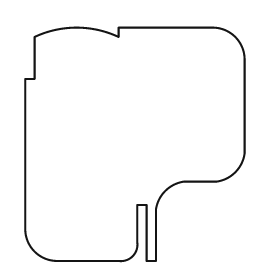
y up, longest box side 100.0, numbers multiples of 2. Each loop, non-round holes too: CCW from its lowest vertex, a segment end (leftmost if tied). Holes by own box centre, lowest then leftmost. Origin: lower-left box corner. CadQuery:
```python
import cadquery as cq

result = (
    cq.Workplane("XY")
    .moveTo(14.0, 0.0)
    .lineTo(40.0, 0.0)
    .threePointArc((46.0, 2.0), (48.0, 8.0))
    .lineTo(48.0, 24.0)
    .lineTo(52.0, 24.0)
    .lineTo(52.0, 0.0)
    .lineTo(56.0, 0.0)
    .lineTo(56.0, 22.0)
    .threePointArc((60.0, 30.0), (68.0, 34.0))
    .lineTo(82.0, 34.0)
    .threePointArc((90.0, 38.0), (94.0, 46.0))
    .lineTo(94.0, 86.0)
    .threePointArc((90.0, 96.0), (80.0, 100.0))
    .lineTo(40.0, 100.0)
    .lineTo(40.0, 96.0)
    .threePointArc((22.0, 100.0), (4.0, 96.0))
    .lineTo(4.0, 78.0)
    .lineTo(0.0, 78.0)
    .lineTo(0.0, 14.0)
    .threePointArc((4.0, 4.0), (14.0, 0.0))
    .close()
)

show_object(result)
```